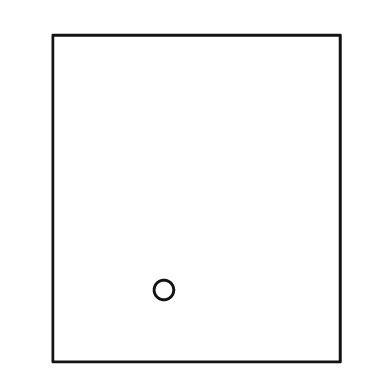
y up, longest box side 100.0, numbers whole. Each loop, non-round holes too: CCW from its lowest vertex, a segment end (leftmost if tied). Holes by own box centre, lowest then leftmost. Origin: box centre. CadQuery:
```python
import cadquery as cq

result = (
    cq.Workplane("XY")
    .moveTo(-44.0, -50.0)
    .lineTo(44.0, -50.0)
    .lineTo(44.0, 50.0)
    .lineTo(-44.0, 50.0)
    .close()
    .moveTo(-10.0, -28.0)
    .circle(3.0)
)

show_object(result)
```